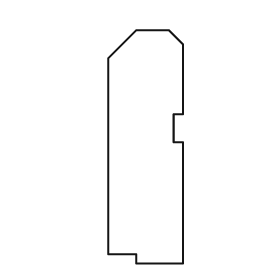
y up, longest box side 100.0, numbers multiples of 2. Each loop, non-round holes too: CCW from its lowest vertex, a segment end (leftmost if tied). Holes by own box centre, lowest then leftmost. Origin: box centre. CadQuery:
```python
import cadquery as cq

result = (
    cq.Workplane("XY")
    .moveTo(-4.0, -50.0)
    .lineTo(16.0, -50.0)
    .lineTo(16.0, 2.0)
    .lineTo(12.0, 2.0)
    .lineTo(12.0, 14.0)
    .lineTo(16.0, 14.0)
    .lineTo(16.0, 44.0)
    .lineTo(10.0, 50.0)
    .lineTo(-4.0, 50.0)
    .lineTo(-16.0, 38.0)
    .lineTo(-16.0, -46.0)
    .lineTo(-4.0, -46.0)
    .close()
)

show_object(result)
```